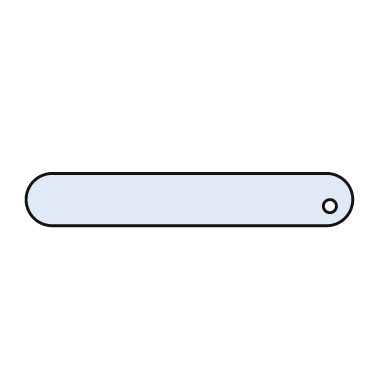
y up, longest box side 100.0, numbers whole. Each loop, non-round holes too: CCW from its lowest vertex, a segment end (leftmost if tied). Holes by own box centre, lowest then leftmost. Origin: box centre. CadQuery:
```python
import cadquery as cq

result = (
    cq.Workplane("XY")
    .moveTo(-42.0, -8.0)
    .lineTo(42.0, -8.0)
    .threePointArc((50.0, 0.0), (42.0, 8.0))
    .lineTo(-42.0, 8.0)
    .threePointArc((-50.0, 0.0), (-42.0, -8.0))
    .close()
    .moveTo(43.0, -2.0)
    .circle(2.0)
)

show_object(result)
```